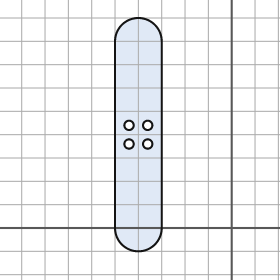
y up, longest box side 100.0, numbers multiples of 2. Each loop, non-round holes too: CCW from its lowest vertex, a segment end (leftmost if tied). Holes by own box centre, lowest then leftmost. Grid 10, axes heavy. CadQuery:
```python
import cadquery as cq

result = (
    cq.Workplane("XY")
    .moveTo(-50.0, 0.0)
    .threePointArc((-40.0, -10.0), (-30.0, 0.0))
    .lineTo(-30.0, 80.0)
    .threePointArc((-40.0, 90.0), (-50.0, 80.0))
    .close()
    .moveTo(-44.0, 36.0)
    .circle(2.0)
    .moveTo(-36.0, 36.0)
    .circle(2.0)
    .moveTo(-44.0, 44.0)
    .circle(2.0)
    .moveTo(-36.0, 44.0)
    .circle(2.0)
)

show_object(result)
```